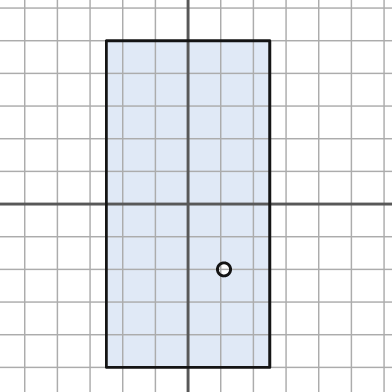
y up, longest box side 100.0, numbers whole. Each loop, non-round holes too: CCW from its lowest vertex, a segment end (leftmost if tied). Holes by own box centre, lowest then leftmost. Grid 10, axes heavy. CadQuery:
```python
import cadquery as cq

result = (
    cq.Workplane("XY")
    .moveTo(-25.0, -50.0)
    .lineTo(25.0, -50.0)
    .lineTo(25.0, 50.0)
    .lineTo(-25.0, 50.0)
    .close()
    .moveTo(11.0, -20.0)
    .circle(2.0)
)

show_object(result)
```